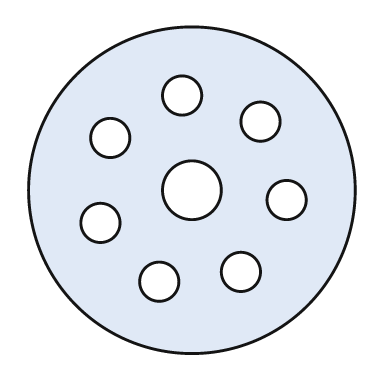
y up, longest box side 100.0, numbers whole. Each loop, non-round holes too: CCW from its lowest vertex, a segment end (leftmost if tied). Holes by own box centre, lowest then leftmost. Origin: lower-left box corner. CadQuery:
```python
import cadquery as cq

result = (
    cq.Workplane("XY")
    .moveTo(50.0, 50.0)
    .circle(50.0)
    .moveTo(40.0, 22.0)
    .circle(6.0)
    .moveTo(65.0, 25.0)
    .circle(6.0)
    .moveTo(22.0, 40.0)
    .circle(6.0)
    .moveTo(79.0, 47.0)
    .circle(6.0)
    .moveTo(50.0, 50.0)
    .circle(9.0)
    .moveTo(25.0, 66.0)
    .circle(6.0)
    .moveTo(71.0, 71.0)
    .circle(6.0)
    .moveTo(47.0, 79.0)
    .circle(6.0)
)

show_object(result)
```